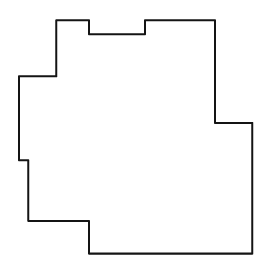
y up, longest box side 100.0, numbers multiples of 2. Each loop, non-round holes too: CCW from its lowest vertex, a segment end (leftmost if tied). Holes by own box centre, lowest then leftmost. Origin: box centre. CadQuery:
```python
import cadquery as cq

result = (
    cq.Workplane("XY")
    .moveTo(-20.0, -50.0)
    .lineTo(50.0, -50.0)
    .lineTo(50.0, 6.0)
    .lineTo(34.0, 6.0)
    .lineTo(34.0, 50.0)
    .lineTo(4.0, 50.0)
    .lineTo(4.0, 44.0)
    .lineTo(-20.0, 44.0)
    .lineTo(-20.0, 50.0)
    .lineTo(-34.0, 50.0)
    .lineTo(-34.0, 26.0)
    .lineTo(-50.0, 26.0)
    .lineTo(-50.0, -10.0)
    .lineTo(-46.0, -10.0)
    .lineTo(-46.0, -36.0)
    .lineTo(-20.0, -36.0)
    .close()
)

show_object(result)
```